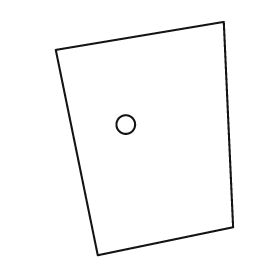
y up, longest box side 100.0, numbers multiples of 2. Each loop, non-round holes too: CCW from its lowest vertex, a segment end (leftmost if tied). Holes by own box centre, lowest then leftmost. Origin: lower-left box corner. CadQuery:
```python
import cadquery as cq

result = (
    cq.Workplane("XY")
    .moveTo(18.0, 0.0)
    .lineTo(76.0, 12.0)
    .lineTo(72.0, 100.0)
    .lineTo(0.0, 88.0)
    .close()
    .moveTo(30.0, 56.0)
    .circle(4.0)
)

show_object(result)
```